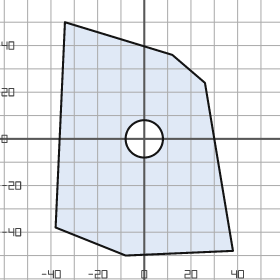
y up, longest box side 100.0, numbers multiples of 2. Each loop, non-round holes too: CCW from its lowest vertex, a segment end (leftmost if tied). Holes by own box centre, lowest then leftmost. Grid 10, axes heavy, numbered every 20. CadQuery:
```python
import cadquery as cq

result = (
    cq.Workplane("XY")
    .moveTo(-8.0, -50.0)
    .lineTo(38.0, -48.0)
    .lineTo(26.0, 24.0)
    .lineTo(12.0, 36.0)
    .lineTo(-34.0, 50.0)
    .lineTo(-38.0, -38.0)
    .close()
    .moveTo(0.0, 0.0)
    .circle(8.0)
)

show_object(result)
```